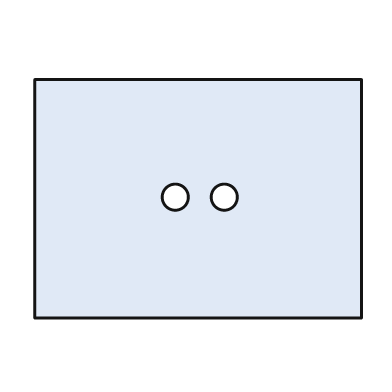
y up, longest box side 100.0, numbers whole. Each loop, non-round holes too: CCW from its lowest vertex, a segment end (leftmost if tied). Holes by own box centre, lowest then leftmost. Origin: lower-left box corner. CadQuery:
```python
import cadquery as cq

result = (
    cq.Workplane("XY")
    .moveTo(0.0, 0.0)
    .lineTo(100.0, 0.0)
    .lineTo(100.0, 73.0)
    .lineTo(0.0, 73.0)
    .close()
    .moveTo(43.0, 37.0)
    .circle(4.0)
    .moveTo(58.0, 37.0)
    .circle(4.0)
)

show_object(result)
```